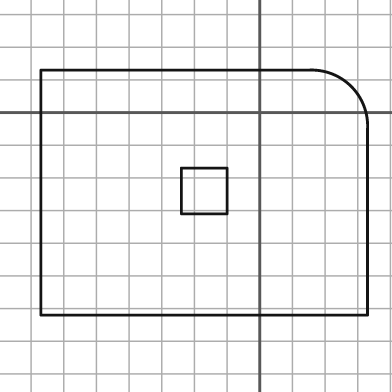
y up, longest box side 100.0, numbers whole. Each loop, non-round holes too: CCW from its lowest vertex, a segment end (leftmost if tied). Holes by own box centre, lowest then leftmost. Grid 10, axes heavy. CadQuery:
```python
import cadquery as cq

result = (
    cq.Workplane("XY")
    .moveTo(-67.0, -62.0)
    .lineTo(33.0, -62.0)
    .lineTo(33.0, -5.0)
    .threePointArc((28.0, 8.0), (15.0, 13.0))
    .lineTo(-67.0, 13.0)
    .close()
    .moveTo(-24.0, -31.0)
    .lineTo(-10.0, -31.0)
    .lineTo(-10.0, -17.0)
    .lineTo(-24.0, -17.0)
    .close()
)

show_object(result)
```